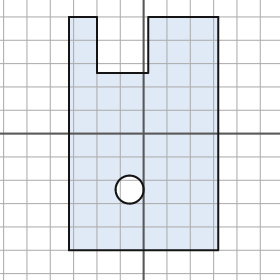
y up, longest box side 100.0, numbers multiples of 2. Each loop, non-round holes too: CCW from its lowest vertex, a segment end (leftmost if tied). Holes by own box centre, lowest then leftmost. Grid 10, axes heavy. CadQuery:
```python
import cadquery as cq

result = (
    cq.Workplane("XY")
    .moveTo(-32.0, -50.0)
    .lineTo(32.0, -50.0)
    .lineTo(32.0, 50.0)
    .lineTo(2.0, 50.0)
    .lineTo(2.0, 26.0)
    .lineTo(-20.0, 26.0)
    .lineTo(-20.0, 50.0)
    .lineTo(-32.0, 50.0)
    .close()
    .moveTo(-6.0, -24.0)
    .circle(6.0)
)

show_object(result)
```